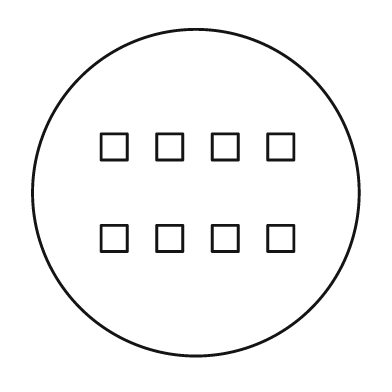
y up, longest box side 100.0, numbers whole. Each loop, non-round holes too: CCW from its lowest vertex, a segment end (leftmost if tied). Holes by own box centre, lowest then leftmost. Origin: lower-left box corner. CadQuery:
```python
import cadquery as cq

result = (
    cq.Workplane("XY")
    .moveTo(50.0, 50.0)
    .circle(50.0)
    .moveTo(21.0, 32.0)
    .lineTo(29.0, 32.0)
    .lineTo(29.0, 40.0)
    .lineTo(21.0, 40.0)
    .close()
    .moveTo(38.0, 32.0)
    .lineTo(46.0, 32.0)
    .lineTo(46.0, 40.0)
    .lineTo(38.0, 40.0)
    .close()
    .moveTo(55.0, 32.0)
    .lineTo(63.0, 32.0)
    .lineTo(63.0, 40.0)
    .lineTo(55.0, 40.0)
    .close()
    .moveTo(72.0, 32.0)
    .lineTo(80.0, 32.0)
    .lineTo(80.0, 40.0)
    .lineTo(72.0, 40.0)
    .close()
    .moveTo(21.0, 60.0)
    .lineTo(29.0, 60.0)
    .lineTo(29.0, 68.0)
    .lineTo(21.0, 68.0)
    .close()
    .moveTo(38.0, 60.0)
    .lineTo(46.0, 60.0)
    .lineTo(46.0, 68.0)
    .lineTo(38.0, 68.0)
    .close()
    .moveTo(55.0, 60.0)
    .lineTo(63.0, 60.0)
    .lineTo(63.0, 68.0)
    .lineTo(55.0, 68.0)
    .close()
    .moveTo(72.0, 60.0)
    .lineTo(80.0, 60.0)
    .lineTo(80.0, 68.0)
    .lineTo(72.0, 68.0)
    .close()
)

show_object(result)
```